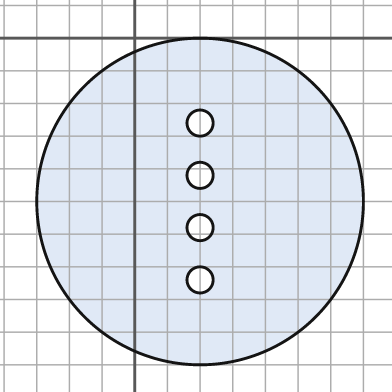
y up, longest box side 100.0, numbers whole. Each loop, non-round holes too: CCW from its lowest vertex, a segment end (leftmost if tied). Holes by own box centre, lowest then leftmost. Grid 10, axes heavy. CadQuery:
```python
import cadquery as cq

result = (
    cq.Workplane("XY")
    .moveTo(20.0, -50.0)
    .circle(50.0)
    .moveTo(20.0, -74.0)
    .circle(4.0)
    .moveTo(20.0, -58.0)
    .circle(4.0)
    .moveTo(20.0, -42.0)
    .circle(4.0)
    .moveTo(20.0, -26.0)
    .circle(4.0)
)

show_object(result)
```